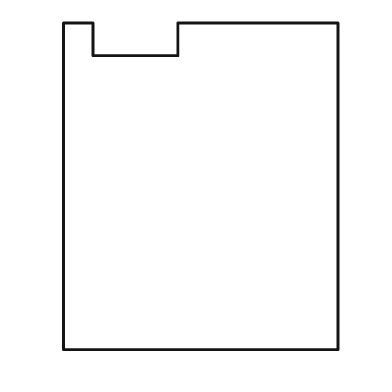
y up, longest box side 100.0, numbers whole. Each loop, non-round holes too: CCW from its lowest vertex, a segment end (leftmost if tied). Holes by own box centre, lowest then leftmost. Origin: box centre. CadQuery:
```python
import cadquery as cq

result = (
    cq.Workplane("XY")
    .moveTo(-42.0, -50.0)
    .lineTo(42.0, -50.0)
    .lineTo(42.0, 50.0)
    .lineTo(-7.0, 50.0)
    .lineTo(-7.0, 40.0)
    .lineTo(-33.0, 40.0)
    .lineTo(-33.0, 50.0)
    .lineTo(-42.0, 50.0)
    .close()
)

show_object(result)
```